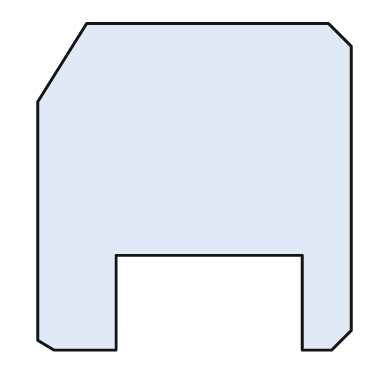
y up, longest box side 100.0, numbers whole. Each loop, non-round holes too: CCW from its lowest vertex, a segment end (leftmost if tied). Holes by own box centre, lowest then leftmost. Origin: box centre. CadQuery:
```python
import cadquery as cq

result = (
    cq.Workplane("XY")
    .moveTo(-43.0, -50.0)
    .lineTo(-24.0, -50.0)
    .lineTo(-24.0, -21.0)
    .lineTo(33.0, -21.0)
    .lineTo(33.0, -50.0)
    .lineTo(42.0, -50.0)
    .lineTo(48.0, -44.0)
    .lineTo(48.0, 43.0)
    .lineTo(41.0, 50.0)
    .lineTo(-33.0, 50.0)
    .lineTo(-48.0, 26.0)
    .lineTo(-48.0, -47.0)
    .close()
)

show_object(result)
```